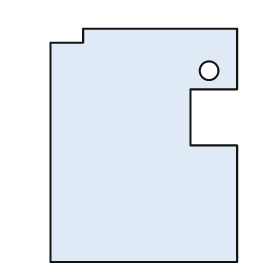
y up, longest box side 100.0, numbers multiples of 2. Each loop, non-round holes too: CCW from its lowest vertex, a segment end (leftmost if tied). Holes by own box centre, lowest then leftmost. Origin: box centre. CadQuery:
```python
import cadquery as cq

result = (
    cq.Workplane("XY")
    .moveTo(-40.0, -50.0)
    .lineTo(40.0, -50.0)
    .lineTo(40.0, 0.0)
    .lineTo(20.0, 0.0)
    .lineTo(20.0, 24.0)
    .lineTo(40.0, 24.0)
    .lineTo(40.0, 50.0)
    .lineTo(-26.0, 50.0)
    .lineTo(-26.0, 44.0)
    .lineTo(-40.0, 44.0)
    .close()
    .moveTo(28.0, 32.0)
    .circle(4.0)
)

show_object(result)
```